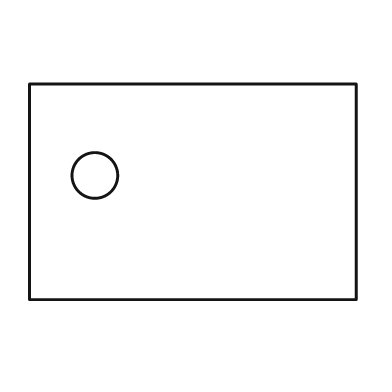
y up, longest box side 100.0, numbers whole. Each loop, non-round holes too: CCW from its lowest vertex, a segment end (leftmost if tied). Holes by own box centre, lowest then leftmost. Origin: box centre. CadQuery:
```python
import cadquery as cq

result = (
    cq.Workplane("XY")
    .moveTo(-50.0, -33.0)
    .lineTo(50.0, -33.0)
    .lineTo(50.0, 33.0)
    .lineTo(-50.0, 33.0)
    .close()
    .moveTo(-30.0, 5.0)
    .circle(7.0)
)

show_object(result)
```